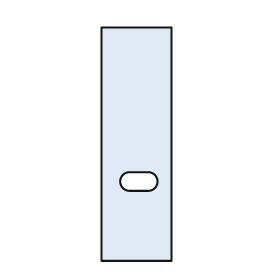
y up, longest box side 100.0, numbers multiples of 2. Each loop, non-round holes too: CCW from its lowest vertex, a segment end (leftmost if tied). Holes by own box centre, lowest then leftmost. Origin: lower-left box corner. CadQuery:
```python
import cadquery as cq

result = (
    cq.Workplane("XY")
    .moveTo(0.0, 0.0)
    .lineTo(30.0, 0.0)
    .lineTo(30.0, 100.0)
    .lineTo(0.0, 100.0)
    .close()
    .moveTo(12.0, 30.0)
    .lineTo(20.0, 30.0)
    .threePointArc((24.0, 34.0), (20.0, 38.0))
    .lineTo(12.0, 38.0)
    .threePointArc((8.0, 34.0), (12.0, 30.0))
    .close()
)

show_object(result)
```